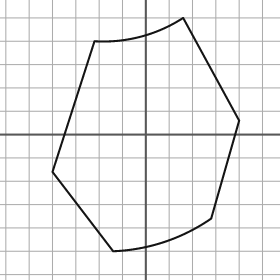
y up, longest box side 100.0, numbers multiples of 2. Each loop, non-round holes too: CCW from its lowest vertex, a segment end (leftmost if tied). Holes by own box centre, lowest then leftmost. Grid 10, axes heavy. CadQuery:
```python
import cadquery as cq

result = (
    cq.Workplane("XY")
    .moveTo(-14.0, -50.0)
    .threePointArc((8.0, -46.0), (28.0, -36.0))
    .lineTo(40.0, 6.0)
    .lineTo(16.0, 50.0)
    .threePointArc((-2.0, 42.0), (-22.0, 40.0))
    .lineTo(-40.0, -16.0)
    .close()
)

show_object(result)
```